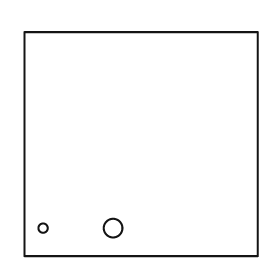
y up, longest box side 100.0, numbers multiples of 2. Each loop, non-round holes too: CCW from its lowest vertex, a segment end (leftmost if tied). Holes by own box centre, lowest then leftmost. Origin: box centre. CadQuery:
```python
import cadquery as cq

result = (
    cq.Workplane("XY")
    .moveTo(-50.0, -48.0)
    .lineTo(50.0, -48.0)
    .lineTo(50.0, 48.0)
    .lineTo(-50.0, 48.0)
    .close()
    .moveTo(-42.0, -36.0)
    .circle(2.0)
    .moveTo(-12.0, -36.0)
    .circle(4.0)
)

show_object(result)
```